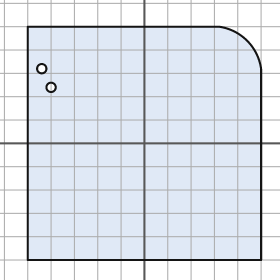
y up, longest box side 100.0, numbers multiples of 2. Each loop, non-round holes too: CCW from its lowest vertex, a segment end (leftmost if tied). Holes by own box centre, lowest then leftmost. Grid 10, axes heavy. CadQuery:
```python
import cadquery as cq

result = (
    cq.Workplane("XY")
    .moveTo(-50.0, -50.0)
    .lineTo(50.0, -50.0)
    .lineTo(50.0, 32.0)
    .threePointArc((44.0, 44.0), (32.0, 50.0))
    .lineTo(-50.0, 50.0)
    .close()
    .moveTo(-40.0, 24.0)
    .circle(2.0)
    .moveTo(-44.0, 32.0)
    .circle(2.0)
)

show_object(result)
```